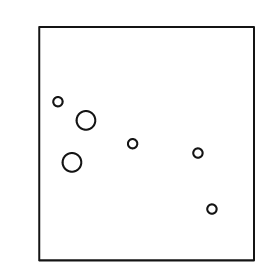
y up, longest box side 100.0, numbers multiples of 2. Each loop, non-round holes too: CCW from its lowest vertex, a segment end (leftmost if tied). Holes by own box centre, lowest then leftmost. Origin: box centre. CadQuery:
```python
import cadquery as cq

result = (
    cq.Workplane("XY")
    .moveTo(-46.0, -50.0)
    .lineTo(46.0, -50.0)
    .lineTo(46.0, 50.0)
    .lineTo(-46.0, 50.0)
    .close()
    .moveTo(28.0, -28.0)
    .circle(2.0)
    .moveTo(-32.0, -8.0)
    .circle(4.0)
    .moveTo(22.0, -4.0)
    .circle(2.0)
    .moveTo(-6.0, 0.0)
    .circle(2.0)
    .moveTo(-26.0, 10.0)
    .circle(4.0)
    .moveTo(-38.0, 18.0)
    .circle(2.0)
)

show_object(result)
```